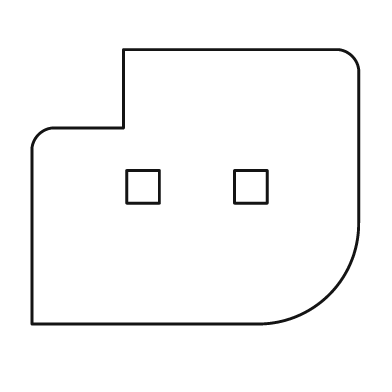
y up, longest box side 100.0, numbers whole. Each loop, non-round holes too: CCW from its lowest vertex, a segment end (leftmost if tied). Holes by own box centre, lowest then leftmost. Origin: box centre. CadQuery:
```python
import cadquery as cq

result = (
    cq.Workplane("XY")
    .moveTo(-50.0, -42.0)
    .lineTo(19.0, -42.0)
    .threePointArc((41.0, -33.0), (50.0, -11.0))
    .lineTo(50.0, 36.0)
    .threePointArc((48.0, 40.0), (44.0, 42.0))
    .lineTo(-22.0, 42.0)
    .lineTo(-22.0, 18.0)
    .lineTo(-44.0, 18.0)
    .threePointArc((-48.0, 16.0), (-50.0, 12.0))
    .close()
    .moveTo(-21.0, -5.0)
    .lineTo(-11.0, -5.0)
    .lineTo(-11.0, 5.0)
    .lineTo(-21.0, 5.0)
    .close()
    .moveTo(12.0, -5.0)
    .lineTo(22.0, -5.0)
    .lineTo(22.0, 5.0)
    .lineTo(12.0, 5.0)
    .close()
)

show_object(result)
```